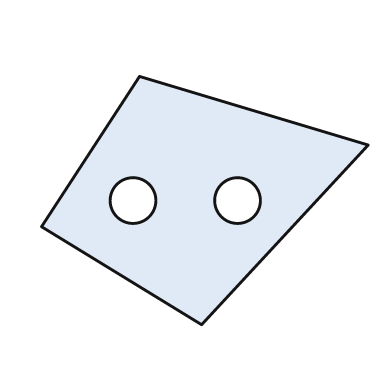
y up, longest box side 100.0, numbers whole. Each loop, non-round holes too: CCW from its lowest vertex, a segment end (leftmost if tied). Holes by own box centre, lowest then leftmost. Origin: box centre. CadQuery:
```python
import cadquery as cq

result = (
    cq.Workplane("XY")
    .moveTo(-1.0, -38.0)
    .lineTo(50.0, 17.0)
    .lineTo(-20.0, 38.0)
    .lineTo(-50.0, -8.0)
    .close()
    .moveTo(-22.0, 0.0)
    .circle(7.0)
    .moveTo(10.0, 0.0)
    .circle(7.0)
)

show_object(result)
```